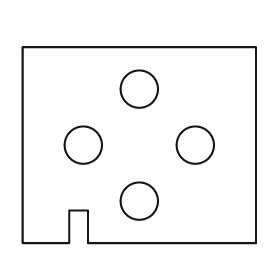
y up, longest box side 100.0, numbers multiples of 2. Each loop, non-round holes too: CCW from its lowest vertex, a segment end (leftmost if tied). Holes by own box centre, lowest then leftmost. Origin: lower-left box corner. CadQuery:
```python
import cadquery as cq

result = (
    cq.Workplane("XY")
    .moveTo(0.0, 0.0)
    .lineTo(20.0, 0.0)
    .lineTo(20.0, 14.0)
    .lineTo(28.0, 14.0)
    .lineTo(28.0, 0.0)
    .lineTo(100.0, 0.0)
    .lineTo(100.0, 84.0)
    .lineTo(0.0, 84.0)
    .close()
    .moveTo(50.0, 18.0)
    .circle(8.0)
    .moveTo(26.0, 42.0)
    .circle(8.0)
    .moveTo(74.0, 42.0)
    .circle(8.0)
    .moveTo(50.0, 66.0)
    .circle(8.0)
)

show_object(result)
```